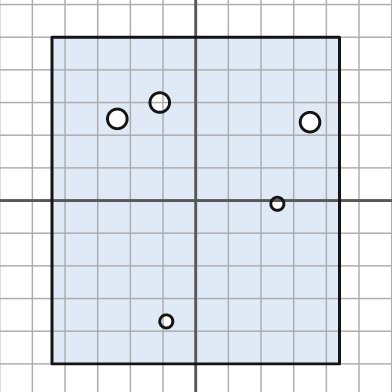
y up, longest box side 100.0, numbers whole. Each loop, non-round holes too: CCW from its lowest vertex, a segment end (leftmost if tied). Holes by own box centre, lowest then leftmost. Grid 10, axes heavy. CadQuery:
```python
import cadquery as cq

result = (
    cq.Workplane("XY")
    .moveTo(-44.0, -50.0)
    .lineTo(44.0, -50.0)
    .lineTo(44.0, 50.0)
    .lineTo(-44.0, 50.0)
    .close()
    .moveTo(-9.0, -37.0)
    .circle(2.0)
    .moveTo(25.0, -1.0)
    .circle(2.0)
    .moveTo(35.0, 24.0)
    .circle(3.0)
    .moveTo(-24.0, 25.0)
    .circle(3.0)
    .moveTo(-11.0, 30.0)
    .circle(3.0)
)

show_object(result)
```